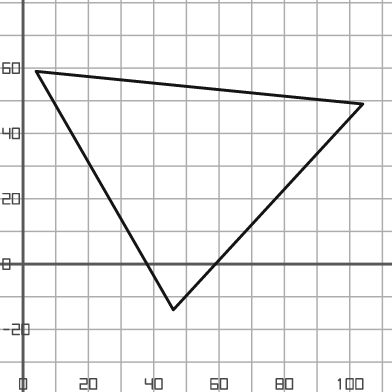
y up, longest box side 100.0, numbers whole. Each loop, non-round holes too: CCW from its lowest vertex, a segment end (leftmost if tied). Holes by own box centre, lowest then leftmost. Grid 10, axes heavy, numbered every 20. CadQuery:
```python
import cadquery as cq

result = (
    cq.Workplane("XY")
    .moveTo(46.0, -14.0)
    .lineTo(104.0, 49.0)
    .lineTo(4.0, 59.0)
    .close()
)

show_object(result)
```